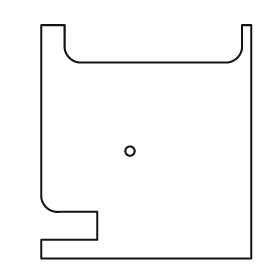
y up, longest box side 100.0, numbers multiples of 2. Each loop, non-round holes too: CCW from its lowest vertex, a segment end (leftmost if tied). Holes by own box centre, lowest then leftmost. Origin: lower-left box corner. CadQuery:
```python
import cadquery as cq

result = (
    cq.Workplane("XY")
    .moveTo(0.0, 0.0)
    .lineTo(90.0, 0.0)
    .lineTo(90.0, 100.0)
    .lineTo(86.0, 100.0)
    .lineTo(86.0, 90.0)
    .threePointArc((84.0, 86.0), (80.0, 84.0))
    .lineTo(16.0, 84.0)
    .threePointArc((12.0, 86.0), (10.0, 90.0))
    .lineTo(10.0, 100.0)
    .lineTo(0.0, 100.0)
    .lineTo(0.0, 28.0)
    .threePointArc((2.0, 22.0), (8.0, 20.0))
    .lineTo(24.0, 20.0)
    .lineTo(24.0, 8.0)
    .lineTo(0.0, 8.0)
    .close()
    .moveTo(38.0, 46.0)
    .circle(2.0)
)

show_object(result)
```